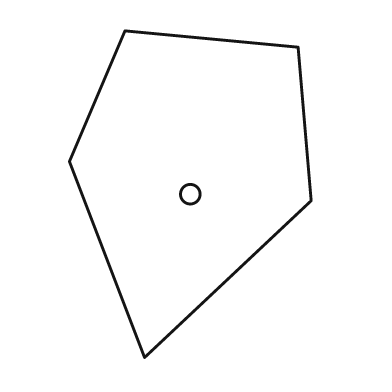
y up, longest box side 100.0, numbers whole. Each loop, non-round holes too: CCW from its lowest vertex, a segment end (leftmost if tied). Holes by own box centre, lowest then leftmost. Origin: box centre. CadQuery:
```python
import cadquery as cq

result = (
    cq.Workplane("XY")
    .moveTo(-14.0, -50.0)
    .lineTo(37.0, -2.0)
    .lineTo(33.0, 45.0)
    .lineTo(-20.0, 50.0)
    .lineTo(-37.0, 10.0)
    .close()
    .moveTo(0.0, 0.0)
    .circle(3.0)
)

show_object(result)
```